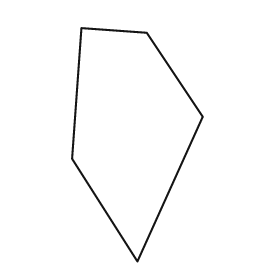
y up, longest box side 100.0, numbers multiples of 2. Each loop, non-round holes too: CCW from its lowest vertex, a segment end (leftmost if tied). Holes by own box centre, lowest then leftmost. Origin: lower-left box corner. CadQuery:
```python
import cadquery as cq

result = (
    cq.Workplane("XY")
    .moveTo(28.0, 0.0)
    .lineTo(56.0, 62.0)
    .lineTo(32.0, 98.0)
    .lineTo(4.0, 100.0)
    .lineTo(0.0, 44.0)
    .close()
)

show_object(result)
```